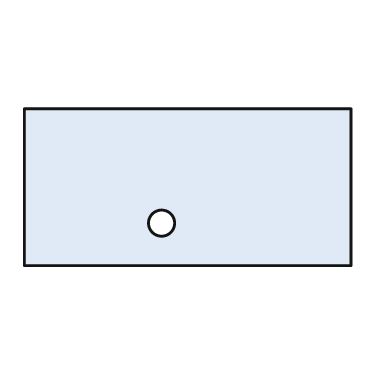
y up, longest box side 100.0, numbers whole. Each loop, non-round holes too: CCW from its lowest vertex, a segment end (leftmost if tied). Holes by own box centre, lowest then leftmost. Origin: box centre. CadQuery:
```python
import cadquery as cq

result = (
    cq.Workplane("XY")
    .moveTo(-50.0, -24.0)
    .lineTo(50.0, -24.0)
    .lineTo(50.0, 24.0)
    .lineTo(-50.0, 24.0)
    .close()
    .moveTo(-8.0, -11.0)
    .circle(4.0)
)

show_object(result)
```